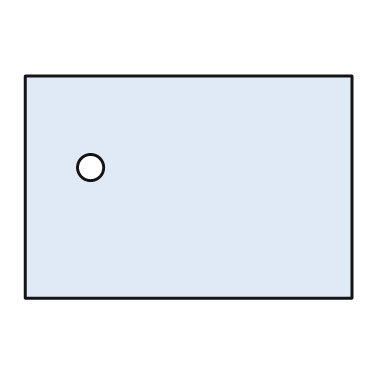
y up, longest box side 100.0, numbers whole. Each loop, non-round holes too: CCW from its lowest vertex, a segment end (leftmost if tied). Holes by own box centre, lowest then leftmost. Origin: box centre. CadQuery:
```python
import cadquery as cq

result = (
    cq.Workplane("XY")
    .moveTo(-50.0, -34.0)
    .lineTo(50.0, -34.0)
    .lineTo(50.0, 34.0)
    .lineTo(-50.0, 34.0)
    .close()
    .moveTo(-30.0, 6.0)
    .circle(4.0)
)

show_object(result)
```